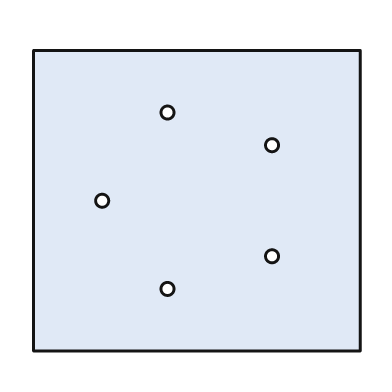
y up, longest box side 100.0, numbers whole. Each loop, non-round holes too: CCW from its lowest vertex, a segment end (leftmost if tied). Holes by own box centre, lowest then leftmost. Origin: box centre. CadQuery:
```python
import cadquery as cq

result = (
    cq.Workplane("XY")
    .moveTo(-50.0, -46.0)
    .lineTo(50.0, -46.0)
    .lineTo(50.0, 46.0)
    .lineTo(-50.0, 46.0)
    .close()
    .moveTo(-9.0, -27.0)
    .circle(2.0)
    .moveTo(23.0, -17.0)
    .circle(2.0)
    .moveTo(-29.0, 0.0)
    .circle(2.0)
    .moveTo(23.0, 17.0)
    .circle(2.0)
    .moveTo(-9.0, 27.0)
    .circle(2.0)
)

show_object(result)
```